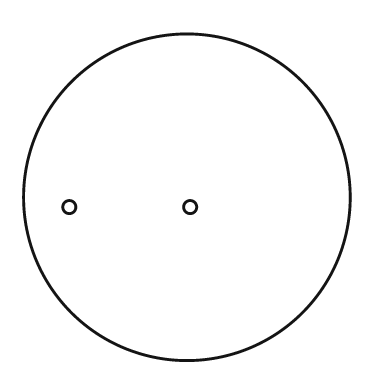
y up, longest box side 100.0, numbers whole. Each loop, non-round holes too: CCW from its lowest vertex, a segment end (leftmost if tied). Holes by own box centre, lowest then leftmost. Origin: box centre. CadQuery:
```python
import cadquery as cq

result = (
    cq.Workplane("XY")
    .moveTo(0.0, 0.0)
    .circle(50.0)
    .moveTo(-36.0, -3.0)
    .circle(2.0)
    .moveTo(1.0, -3.0)
    .circle(2.0)
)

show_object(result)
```